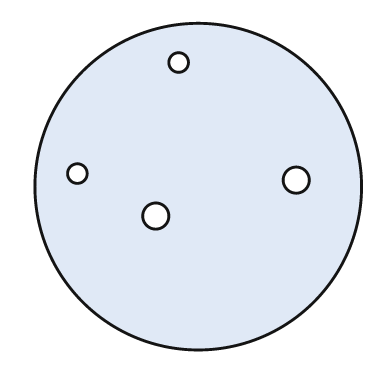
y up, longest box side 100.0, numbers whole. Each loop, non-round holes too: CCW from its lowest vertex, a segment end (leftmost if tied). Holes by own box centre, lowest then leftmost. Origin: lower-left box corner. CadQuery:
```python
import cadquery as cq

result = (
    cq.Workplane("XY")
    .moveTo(50.0, 50.0)
    .circle(50.0)
    .moveTo(37.0, 41.0)
    .circle(4.0)
    .moveTo(80.0, 52.0)
    .circle(4.0)
    .moveTo(13.0, 54.0)
    .circle(3.0)
    .moveTo(44.0, 88.0)
    .circle(3.0)
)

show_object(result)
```